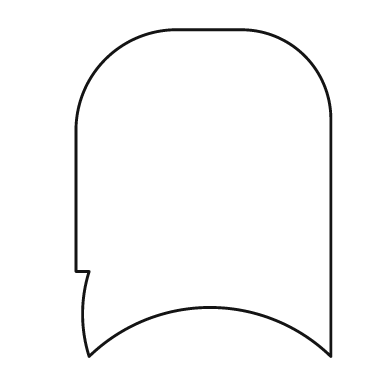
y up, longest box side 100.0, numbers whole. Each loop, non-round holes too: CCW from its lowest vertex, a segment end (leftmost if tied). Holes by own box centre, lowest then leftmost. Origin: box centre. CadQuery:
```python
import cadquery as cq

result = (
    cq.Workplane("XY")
    .moveTo(-35.0, -50.0)
    .threePointArc((2.0, -35.0), (39.0, -50.0))
    .lineTo(39.0, 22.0)
    .threePointArc((31.0, 42.0), (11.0, 50.0))
    .lineTo(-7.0, 50.0)
    .threePointArc((-30.0, 41.0), (-39.0, 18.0))
    .lineTo(-39.0, -24.0)
    .lineTo(-35.0, -24.0)
    .threePointArc((-37.0, -37.0), (-35.0, -50.0))
    .close()
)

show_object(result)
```